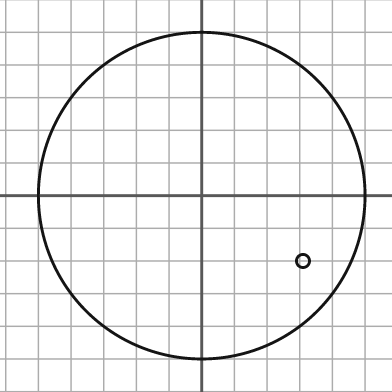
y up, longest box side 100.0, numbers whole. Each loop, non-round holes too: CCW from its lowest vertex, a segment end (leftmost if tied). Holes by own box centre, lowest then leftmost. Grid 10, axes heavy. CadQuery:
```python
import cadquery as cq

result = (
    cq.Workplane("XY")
    .moveTo(0.0, 0.0)
    .circle(50.0)
    .moveTo(31.0, -20.0)
    .circle(2.0)
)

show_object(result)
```